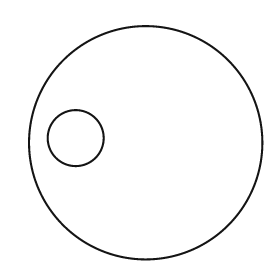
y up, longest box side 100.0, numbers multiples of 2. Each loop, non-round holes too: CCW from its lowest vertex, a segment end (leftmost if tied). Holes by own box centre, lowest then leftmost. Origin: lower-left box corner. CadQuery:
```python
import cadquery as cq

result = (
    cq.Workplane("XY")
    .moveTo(50.0, 50.0)
    .circle(50.0)
    .moveTo(20.0, 52.0)
    .circle(12.0)
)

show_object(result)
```